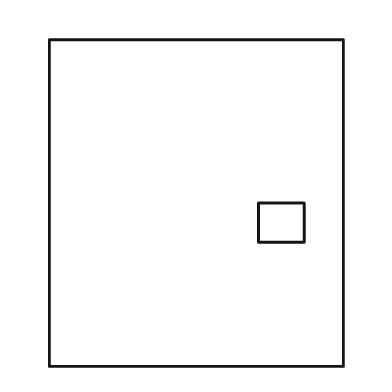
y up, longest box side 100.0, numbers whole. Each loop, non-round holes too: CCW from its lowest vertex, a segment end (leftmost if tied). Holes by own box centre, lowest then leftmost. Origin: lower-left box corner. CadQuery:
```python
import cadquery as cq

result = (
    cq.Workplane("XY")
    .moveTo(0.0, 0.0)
    .lineTo(90.0, 0.0)
    .lineTo(90.0, 100.0)
    .lineTo(0.0, 100.0)
    .close()
    .moveTo(64.0, 38.0)
    .lineTo(78.0, 38.0)
    .lineTo(78.0, 50.0)
    .lineTo(64.0, 50.0)
    .close()
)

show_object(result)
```